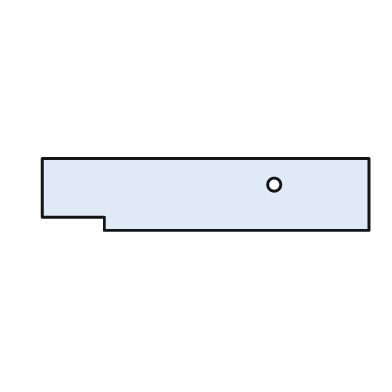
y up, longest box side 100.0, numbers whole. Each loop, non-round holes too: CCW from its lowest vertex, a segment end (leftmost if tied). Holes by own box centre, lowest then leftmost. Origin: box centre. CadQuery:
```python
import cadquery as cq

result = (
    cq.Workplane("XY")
    .moveTo(-31.0, -11.0)
    .lineTo(50.0, -11.0)
    .lineTo(50.0, 11.0)
    .lineTo(-50.0, 11.0)
    .lineTo(-50.0, -7.0)
    .lineTo(-31.0, -7.0)
    .close()
    .moveTo(21.0, 3.0)
    .circle(2.0)
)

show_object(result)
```